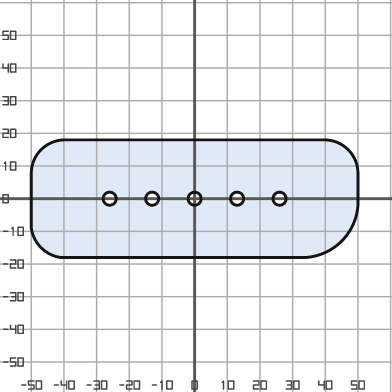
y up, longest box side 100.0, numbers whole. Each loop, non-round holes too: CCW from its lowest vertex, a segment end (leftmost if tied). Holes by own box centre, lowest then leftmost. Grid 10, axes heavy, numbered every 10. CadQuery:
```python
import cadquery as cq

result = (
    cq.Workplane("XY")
    .moveTo(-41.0, -18.0)
    .lineTo(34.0, -18.0)
    .threePointArc((45.0, -13.0), (50.0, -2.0))
    .lineTo(50.0, 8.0)
    .threePointArc((47.0, 15.0), (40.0, 18.0))
    .lineTo(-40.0, 18.0)
    .threePointArc((-47.0, 15.0), (-50.0, 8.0))
    .lineTo(-50.0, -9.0)
    .threePointArc((-47.0, -15.0), (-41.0, -18.0))
    .close()
    .moveTo(-26.0, 0.0)
    .circle(2.0)
    .moveTo(-13.0, 0.0)
    .circle(2.0)
    .moveTo(0.0, 0.0)
    .circle(2.0)
    .moveTo(13.0, 0.0)
    .circle(2.0)
    .moveTo(26.0, 0.0)
    .circle(2.0)
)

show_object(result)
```